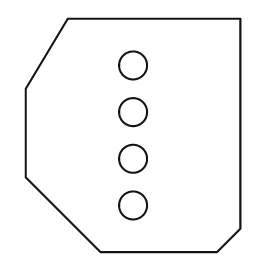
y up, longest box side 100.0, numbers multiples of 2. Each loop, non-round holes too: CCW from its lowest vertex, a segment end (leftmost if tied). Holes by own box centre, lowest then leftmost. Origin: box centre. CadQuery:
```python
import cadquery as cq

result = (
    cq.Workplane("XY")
    .moveTo(-14.0, -50.0)
    .lineTo(36.0, -50.0)
    .lineTo(46.0, -40.0)
    .lineTo(46.0, 50.0)
    .lineTo(-28.0, 50.0)
    .lineTo(-46.0, 20.0)
    .lineTo(-46.0, -18.0)
    .close()
    .moveTo(0.0, -30.0)
    .circle(6.0)
    .moveTo(0.0, -10.0)
    .circle(6.0)
    .moveTo(0.0, 10.0)
    .circle(6.0)
    .moveTo(0.0, 30.0)
    .circle(6.0)
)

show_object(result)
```